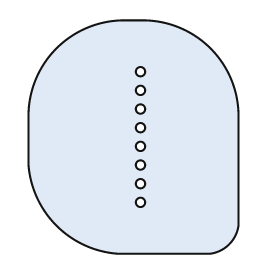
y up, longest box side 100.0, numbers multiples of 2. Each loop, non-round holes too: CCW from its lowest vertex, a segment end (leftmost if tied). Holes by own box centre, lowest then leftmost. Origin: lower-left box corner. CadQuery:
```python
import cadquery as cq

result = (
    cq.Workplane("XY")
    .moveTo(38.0, 0.0)
    .lineTo(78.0, 0.0)
    .threePointArc((86.0, 4.0), (90.0, 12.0))
    .lineTo(90.0, 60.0)
    .threePointArc((78.0, 88.0), (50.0, 100.0))
    .lineTo(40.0, 100.0)
    .threePointArc((12.0, 88.0), (0.0, 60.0))
    .lineTo(0.0, 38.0)
    .threePointArc((12.0, 12.0), (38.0, 0.0))
    .close()
    .moveTo(48.0, 22.0)
    .circle(2.0)
    .moveTo(48.0, 30.0)
    .circle(2.0)
    .moveTo(48.0, 38.0)
    .circle(2.0)
    .moveTo(48.0, 46.0)
    .circle(2.0)
    .moveTo(48.0, 54.0)
    .circle(2.0)
    .moveTo(48.0, 62.0)
    .circle(2.0)
    .moveTo(48.0, 70.0)
    .circle(2.0)
    .moveTo(48.0, 78.0)
    .circle(2.0)
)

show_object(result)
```